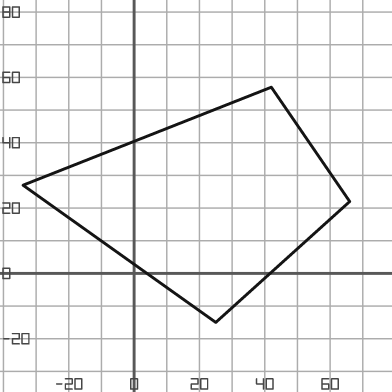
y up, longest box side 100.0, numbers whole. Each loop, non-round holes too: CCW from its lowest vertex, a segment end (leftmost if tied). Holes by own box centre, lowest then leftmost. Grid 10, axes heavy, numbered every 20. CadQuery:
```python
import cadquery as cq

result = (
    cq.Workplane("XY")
    .moveTo(25.0, -15.0)
    .lineTo(66.0, 22.0)
    .lineTo(42.0, 57.0)
    .lineTo(-34.0, 27.0)
    .close()
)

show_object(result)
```